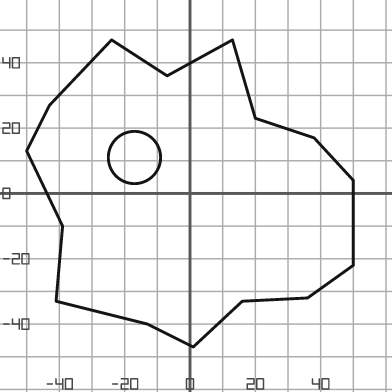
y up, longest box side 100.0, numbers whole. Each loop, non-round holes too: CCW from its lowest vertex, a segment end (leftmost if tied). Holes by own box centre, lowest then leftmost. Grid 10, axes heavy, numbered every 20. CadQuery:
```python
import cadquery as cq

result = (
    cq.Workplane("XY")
    .moveTo(1.0, -47.0)
    .lineTo(16.0, -33.0)
    .lineTo(36.0, -32.0)
    .lineTo(50.0, -22.0)
    .lineTo(50.0, 4.0)
    .lineTo(38.0, 17.0)
    .lineTo(20.0, 23.0)
    .lineTo(13.0, 47.0)
    .lineTo(-7.0, 36.0)
    .lineTo(-24.0, 47.0)
    .lineTo(-43.0, 27.0)
    .lineTo(-50.0, 13.0)
    .lineTo(-39.0, -10.0)
    .lineTo(-41.0, -33.0)
    .lineTo(-13.0, -40.0)
    .close()
    .moveTo(-17.0, 11.0)
    .circle(8.0)
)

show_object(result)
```